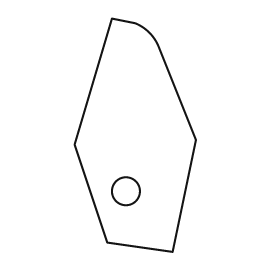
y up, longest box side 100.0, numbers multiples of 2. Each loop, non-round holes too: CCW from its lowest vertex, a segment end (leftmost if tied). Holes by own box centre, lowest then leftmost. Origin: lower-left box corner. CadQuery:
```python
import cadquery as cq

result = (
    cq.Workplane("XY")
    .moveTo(42.0, 0.0)
    .lineTo(52.0, 48.0)
    .lineTo(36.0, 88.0)
    .threePointArc((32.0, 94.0), (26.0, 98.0))
    .lineTo(16.0, 100.0)
    .lineTo(0.0, 46.0)
    .lineTo(14.0, 4.0)
    .close()
    .moveTo(22.0, 26.0)
    .circle(6.0)
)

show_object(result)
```